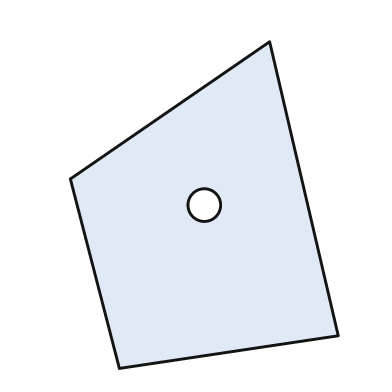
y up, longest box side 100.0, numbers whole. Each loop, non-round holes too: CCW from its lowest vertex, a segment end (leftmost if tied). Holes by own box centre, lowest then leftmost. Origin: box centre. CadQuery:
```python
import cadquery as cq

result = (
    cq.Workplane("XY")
    .moveTo(-26.0, -50.0)
    .lineTo(41.0, -40.0)
    .lineTo(20.0, 50.0)
    .lineTo(-41.0, 8.0)
    .close()
    .moveTo(0.0, 0.0)
    .circle(5.0)
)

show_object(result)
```